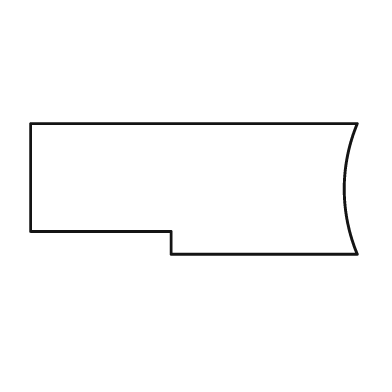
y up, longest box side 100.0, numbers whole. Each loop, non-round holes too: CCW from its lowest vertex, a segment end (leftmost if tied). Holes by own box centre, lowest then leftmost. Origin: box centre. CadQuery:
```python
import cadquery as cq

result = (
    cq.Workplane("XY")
    .moveTo(-7.0, -20.0)
    .lineTo(50.0, -20.0)
    .threePointArc((46.0, 0.0), (50.0, 20.0))
    .lineTo(-50.0, 20.0)
    .lineTo(-50.0, -13.0)
    .lineTo(-7.0, -13.0)
    .close()
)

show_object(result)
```